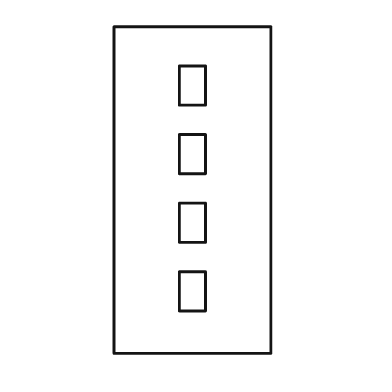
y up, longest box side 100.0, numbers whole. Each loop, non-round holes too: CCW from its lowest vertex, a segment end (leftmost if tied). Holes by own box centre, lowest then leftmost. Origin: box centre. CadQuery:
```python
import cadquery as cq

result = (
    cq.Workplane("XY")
    .moveTo(-24.0, -50.0)
    .lineTo(24.0, -50.0)
    .lineTo(24.0, 50.0)
    .lineTo(-24.0, 50.0)
    .close()
    .moveTo(-4.0, -37.0)
    .lineTo(4.0, -37.0)
    .lineTo(4.0, -25.0)
    .lineTo(-4.0, -25.0)
    .close()
    .moveTo(-4.0, -16.0)
    .lineTo(4.0, -16.0)
    .lineTo(4.0, -4.0)
    .lineTo(-4.0, -4.0)
    .close()
    .moveTo(-4.0, 5.0)
    .lineTo(4.0, 5.0)
    .lineTo(4.0, 17.0)
    .lineTo(-4.0, 17.0)
    .close()
    .moveTo(-4.0, 26.0)
    .lineTo(4.0, 26.0)
    .lineTo(4.0, 38.0)
    .lineTo(-4.0, 38.0)
    .close()
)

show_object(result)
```